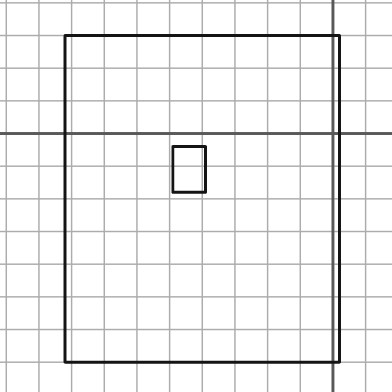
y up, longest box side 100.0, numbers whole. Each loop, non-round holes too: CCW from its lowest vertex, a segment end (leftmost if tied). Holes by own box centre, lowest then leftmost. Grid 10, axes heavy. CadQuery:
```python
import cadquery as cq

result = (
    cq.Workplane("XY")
    .moveTo(-82.0, -70.0)
    .lineTo(2.0, -70.0)
    .lineTo(2.0, 30.0)
    .lineTo(-82.0, 30.0)
    .close()
    .moveTo(-49.0, -18.0)
    .lineTo(-39.0, -18.0)
    .lineTo(-39.0, -4.0)
    .lineTo(-49.0, -4.0)
    .close()
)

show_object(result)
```